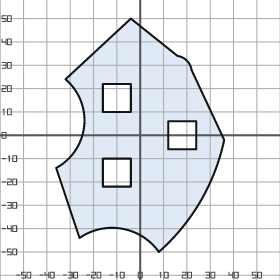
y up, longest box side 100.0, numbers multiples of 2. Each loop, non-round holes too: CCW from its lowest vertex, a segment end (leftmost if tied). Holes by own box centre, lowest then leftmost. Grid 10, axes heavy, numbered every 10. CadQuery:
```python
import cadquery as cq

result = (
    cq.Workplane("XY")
    .moveTo(8.0, -50.0)
    .threePointArc((26.0, -28.0), (36.0, -2.0))
    .lineTo(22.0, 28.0)
    .threePointArc((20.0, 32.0), (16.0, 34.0))
    .lineTo(-4.0, 50.0)
    .lineTo(-32.0, 24.0)
    .threePointArc((-24.0, 4.0), (-36.0, -14.0))
    .lineTo(-26.0, -44.0)
    .threePointArc((-8.0, -40.0), (8.0, -50.0))
    .close()
    .moveTo(-16.0, -22.0)
    .lineTo(-4.0, -22.0)
    .lineTo(-4.0, -10.0)
    .lineTo(-16.0, -10.0)
    .close()
    .moveTo(12.0, -6.0)
    .lineTo(24.0, -6.0)
    .lineTo(24.0, 6.0)
    .lineTo(12.0, 6.0)
    .close()
    .moveTo(-16.0, 10.0)
    .lineTo(-4.0, 10.0)
    .lineTo(-4.0, 22.0)
    .lineTo(-16.0, 22.0)
    .close()
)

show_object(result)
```